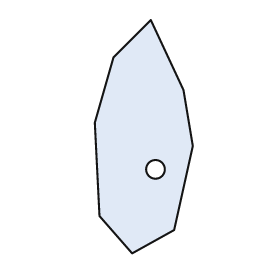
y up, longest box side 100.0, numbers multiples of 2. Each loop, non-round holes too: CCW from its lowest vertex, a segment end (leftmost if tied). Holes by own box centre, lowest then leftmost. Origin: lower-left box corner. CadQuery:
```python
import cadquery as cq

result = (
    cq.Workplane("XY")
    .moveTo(16.0, 0.0)
    .lineTo(34.0, 10.0)
    .lineTo(42.0, 46.0)
    .lineTo(38.0, 70.0)
    .lineTo(24.0, 100.0)
    .lineTo(8.0, 84.0)
    .lineTo(0.0, 56.0)
    .lineTo(2.0, 16.0)
    .close()
    .moveTo(26.0, 36.0)
    .circle(4.0)
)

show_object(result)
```